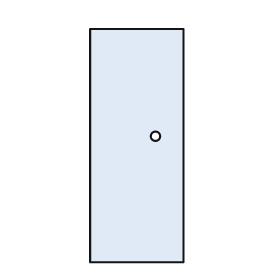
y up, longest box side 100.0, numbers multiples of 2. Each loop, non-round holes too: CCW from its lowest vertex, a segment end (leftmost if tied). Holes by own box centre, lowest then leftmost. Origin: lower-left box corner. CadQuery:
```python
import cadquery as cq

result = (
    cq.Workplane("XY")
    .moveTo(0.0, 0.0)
    .lineTo(40.0, 0.0)
    .lineTo(40.0, 100.0)
    .lineTo(0.0, 100.0)
    .close()
    .moveTo(28.0, 54.0)
    .circle(2.0)
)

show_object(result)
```